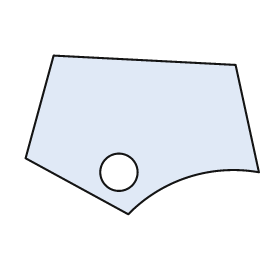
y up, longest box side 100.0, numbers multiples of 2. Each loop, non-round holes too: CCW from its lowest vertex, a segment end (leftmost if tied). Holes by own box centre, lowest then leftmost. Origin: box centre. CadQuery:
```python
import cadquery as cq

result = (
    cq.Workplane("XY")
    .moveTo(-6.0, -34.0)
    .threePointArc((20.0, -18.0), (50.0, -16.0))
    .lineTo(40.0, 30.0)
    .lineTo(-38.0, 34.0)
    .lineTo(-50.0, -10.0)
    .close()
    .moveTo(-10.0, -16.0)
    .circle(8.0)
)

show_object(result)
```